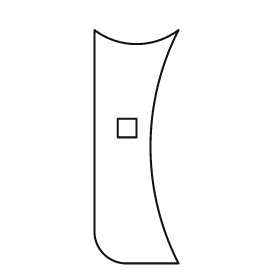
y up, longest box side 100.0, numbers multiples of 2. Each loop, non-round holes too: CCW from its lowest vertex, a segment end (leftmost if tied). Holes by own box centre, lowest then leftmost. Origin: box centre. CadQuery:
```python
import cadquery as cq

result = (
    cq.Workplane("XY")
    .moveTo(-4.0, -50.0)
    .lineTo(18.0, -50.0)
    .threePointArc((6.0, 0.0), (18.0, 50.0))
    .threePointArc((0.0, 44.0), (-18.0, 50.0))
    .lineTo(-18.0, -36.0)
    .threePointArc((-14.0, -46.0), (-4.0, -50.0))
    .close()
    .moveTo(-8.0, 4.0)
    .lineTo(0.0, 4.0)
    .lineTo(0.0, 12.0)
    .lineTo(-8.0, 12.0)
    .close()
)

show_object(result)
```